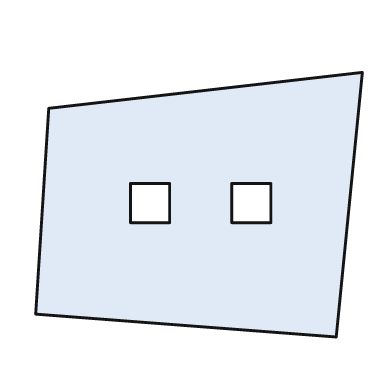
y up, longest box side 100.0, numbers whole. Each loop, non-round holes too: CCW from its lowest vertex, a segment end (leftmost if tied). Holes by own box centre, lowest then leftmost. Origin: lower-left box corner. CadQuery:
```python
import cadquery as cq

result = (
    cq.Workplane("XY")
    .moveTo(92.0, 0.0)
    .lineTo(100.0, 81.0)
    .lineTo(4.0, 70.0)
    .lineTo(0.0, 7.0)
    .close()
    .moveTo(29.0, 35.0)
    .lineTo(41.0, 35.0)
    .lineTo(41.0, 47.0)
    .lineTo(29.0, 47.0)
    .close()
    .moveTo(60.0, 35.0)
    .lineTo(72.0, 35.0)
    .lineTo(72.0, 47.0)
    .lineTo(60.0, 47.0)
    .close()
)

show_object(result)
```